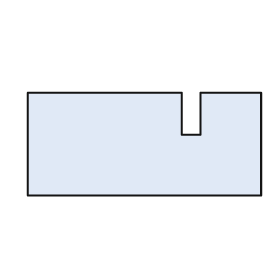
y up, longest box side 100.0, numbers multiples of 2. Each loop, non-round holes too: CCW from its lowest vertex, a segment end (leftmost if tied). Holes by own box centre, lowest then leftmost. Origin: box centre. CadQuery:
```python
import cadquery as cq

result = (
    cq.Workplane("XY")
    .moveTo(-50.0, -22.0)
    .lineTo(50.0, -22.0)
    .lineTo(50.0, 22.0)
    .lineTo(24.0, 22.0)
    .lineTo(24.0, 4.0)
    .lineTo(16.0, 4.0)
    .lineTo(16.0, 22.0)
    .lineTo(-50.0, 22.0)
    .close()
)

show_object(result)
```